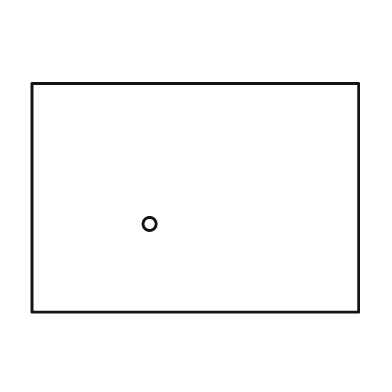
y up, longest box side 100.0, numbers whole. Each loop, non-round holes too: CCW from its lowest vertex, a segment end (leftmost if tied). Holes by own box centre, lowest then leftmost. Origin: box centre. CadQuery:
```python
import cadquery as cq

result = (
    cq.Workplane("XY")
    .moveTo(-50.0, -35.0)
    .lineTo(50.0, -35.0)
    .lineTo(50.0, 35.0)
    .lineTo(-50.0, 35.0)
    .close()
    .moveTo(-14.0, -8.0)
    .circle(2.0)
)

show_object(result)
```